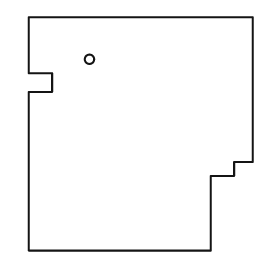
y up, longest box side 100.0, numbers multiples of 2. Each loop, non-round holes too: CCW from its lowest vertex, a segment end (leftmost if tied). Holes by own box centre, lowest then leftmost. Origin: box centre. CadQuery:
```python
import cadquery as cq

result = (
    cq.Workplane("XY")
    .moveTo(-48.0, -50.0)
    .lineTo(30.0, -50.0)
    .lineTo(30.0, -18.0)
    .lineTo(40.0, -18.0)
    .lineTo(40.0, -12.0)
    .lineTo(48.0, -12.0)
    .lineTo(48.0, 50.0)
    .lineTo(-48.0, 50.0)
    .lineTo(-48.0, 26.0)
    .lineTo(-38.0, 26.0)
    .lineTo(-38.0, 18.0)
    .lineTo(-48.0, 18.0)
    .close()
    .moveTo(-22.0, 32.0)
    .circle(2.0)
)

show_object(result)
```